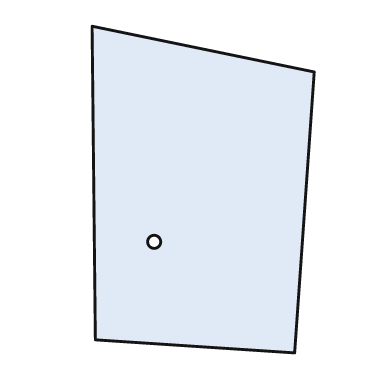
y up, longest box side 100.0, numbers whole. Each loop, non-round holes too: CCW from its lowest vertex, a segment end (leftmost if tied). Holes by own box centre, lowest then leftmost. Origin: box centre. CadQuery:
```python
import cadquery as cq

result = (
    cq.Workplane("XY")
    .moveTo(28.0, -50.0)
    .lineTo(34.0, 36.0)
    .lineTo(-34.0, 50.0)
    .lineTo(-33.0, -46.0)
    .close()
    .moveTo(-15.0, -16.0)
    .circle(2.0)
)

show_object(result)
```